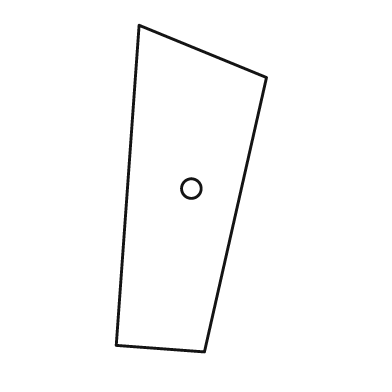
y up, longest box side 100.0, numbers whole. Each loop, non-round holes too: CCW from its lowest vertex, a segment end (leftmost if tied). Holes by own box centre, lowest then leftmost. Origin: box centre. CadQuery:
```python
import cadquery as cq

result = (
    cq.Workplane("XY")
    .moveTo(4.0, -50.0)
    .lineTo(23.0, 34.0)
    .lineTo(-16.0, 50.0)
    .lineTo(-23.0, -48.0)
    .close()
    .moveTo(0.0, 0.0)
    .circle(3.0)
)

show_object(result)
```